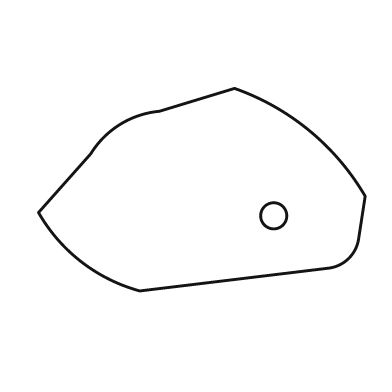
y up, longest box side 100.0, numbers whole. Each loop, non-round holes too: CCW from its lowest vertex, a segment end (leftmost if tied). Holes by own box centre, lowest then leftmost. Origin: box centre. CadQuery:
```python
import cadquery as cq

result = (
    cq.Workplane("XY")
    .moveTo(-19.0, -31.0)
    .lineTo(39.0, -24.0)
    .threePointArc((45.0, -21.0), (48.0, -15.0))
    .lineTo(50.0, -2.0)
    .threePointArc((33.0, 18.0), (10.0, 31.0))
    .lineTo(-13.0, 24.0)
    .threePointArc((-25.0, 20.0), (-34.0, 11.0))
    .lineTo(-50.0, -7.0)
    .threePointArc((-37.0, -22.0), (-19.0, -31.0))
    .close()
    .moveTo(22.0, -8.0)
    .circle(4.0)
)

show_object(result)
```